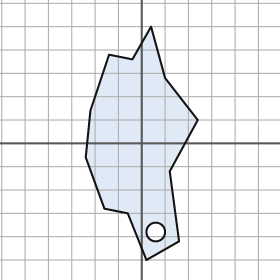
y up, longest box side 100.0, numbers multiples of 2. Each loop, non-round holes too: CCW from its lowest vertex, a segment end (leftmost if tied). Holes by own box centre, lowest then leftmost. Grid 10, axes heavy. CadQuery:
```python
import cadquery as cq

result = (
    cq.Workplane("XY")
    .moveTo(2.0, -50.0)
    .lineTo(16.0, -42.0)
    .lineTo(12.0, -12.0)
    .lineTo(24.0, 10.0)
    .lineTo(10.0, 28.0)
    .lineTo(4.0, 50.0)
    .lineTo(-4.0, 36.0)
    .lineTo(-14.0, 38.0)
    .lineTo(-22.0, 14.0)
    .lineTo(-24.0, -6.0)
    .lineTo(-16.0, -28.0)
    .lineTo(-6.0, -30.0)
    .close()
    .moveTo(6.0, -38.0)
    .circle(4.0)
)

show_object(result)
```